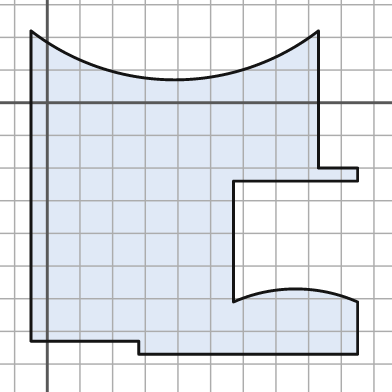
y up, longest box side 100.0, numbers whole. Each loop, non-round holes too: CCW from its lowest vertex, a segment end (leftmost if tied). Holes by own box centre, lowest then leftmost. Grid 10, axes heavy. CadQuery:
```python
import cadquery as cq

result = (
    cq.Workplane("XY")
    .moveTo(28.0, -77.0)
    .lineTo(95.0, -77.0)
    .lineTo(95.0, -61.0)
    .threePointArc((76.0, -57.0), (57.0, -61.0))
    .lineTo(57.0, -24.0)
    .lineTo(95.0, -24.0)
    .lineTo(95.0, -20.0)
    .lineTo(83.0, -20.0)
    .lineTo(83.0, 22.0)
    .threePointArc((39.0, 7.0), (-5.0, 22.0))
    .lineTo(-5.0, -73.0)
    .lineTo(28.0, -73.0)
    .close()
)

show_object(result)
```